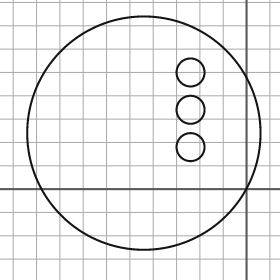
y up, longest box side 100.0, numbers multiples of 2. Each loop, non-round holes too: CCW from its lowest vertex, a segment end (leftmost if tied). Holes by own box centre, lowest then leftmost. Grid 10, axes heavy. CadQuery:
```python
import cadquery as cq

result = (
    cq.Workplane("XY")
    .moveTo(-44.0, 24.0)
    .circle(50.0)
    .moveTo(-24.0, 18.0)
    .circle(6.0)
    .moveTo(-24.0, 34.0)
    .circle(6.0)
    .moveTo(-24.0, 50.0)
    .circle(6.0)
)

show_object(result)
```